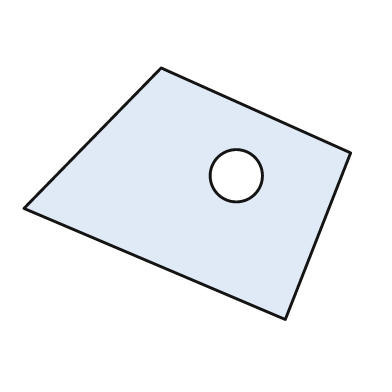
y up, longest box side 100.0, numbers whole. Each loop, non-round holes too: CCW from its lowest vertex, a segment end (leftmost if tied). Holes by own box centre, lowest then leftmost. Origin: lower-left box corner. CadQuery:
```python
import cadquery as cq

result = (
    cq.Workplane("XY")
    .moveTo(80.0, 0.0)
    .lineTo(100.0, 51.0)
    .lineTo(42.0, 77.0)
    .lineTo(0.0, 34.0)
    .close()
    .moveTo(65.0, 44.0)
    .circle(8.0)
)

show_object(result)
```